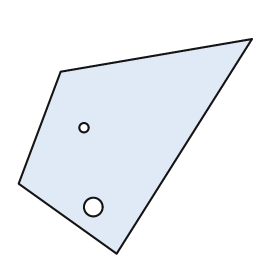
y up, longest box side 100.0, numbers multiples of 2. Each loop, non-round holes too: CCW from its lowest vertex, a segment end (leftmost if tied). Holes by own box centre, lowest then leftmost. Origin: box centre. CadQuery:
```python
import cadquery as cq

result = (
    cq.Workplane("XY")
    .moveTo(-8.0, -46.0)
    .lineTo(50.0, 46.0)
    .lineTo(-32.0, 32.0)
    .lineTo(-50.0, -16.0)
    .close()
    .moveTo(-18.0, -26.0)
    .circle(4.0)
    .moveTo(-22.0, 8.0)
    .circle(2.0)
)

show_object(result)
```